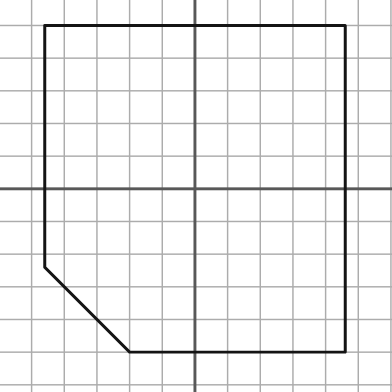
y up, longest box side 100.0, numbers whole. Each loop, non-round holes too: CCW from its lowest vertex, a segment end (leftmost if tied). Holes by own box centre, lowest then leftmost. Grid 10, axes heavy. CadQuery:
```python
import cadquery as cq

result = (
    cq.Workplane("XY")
    .moveTo(-20.0, -50.0)
    .lineTo(46.0, -50.0)
    .lineTo(46.0, 50.0)
    .lineTo(-46.0, 50.0)
    .lineTo(-46.0, -24.0)
    .close()
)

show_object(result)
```